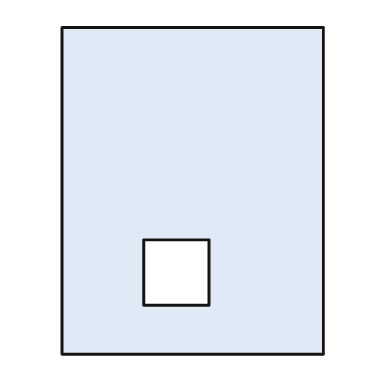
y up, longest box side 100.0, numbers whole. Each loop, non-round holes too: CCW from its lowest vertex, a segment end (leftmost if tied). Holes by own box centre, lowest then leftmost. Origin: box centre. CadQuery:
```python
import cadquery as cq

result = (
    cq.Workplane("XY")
    .moveTo(-40.0, -50.0)
    .lineTo(40.0, -50.0)
    .lineTo(40.0, 50.0)
    .lineTo(-40.0, 50.0)
    .close()
    .moveTo(-15.0, -35.0)
    .lineTo(5.0, -35.0)
    .lineTo(5.0, -15.0)
    .lineTo(-15.0, -15.0)
    .close()
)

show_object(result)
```